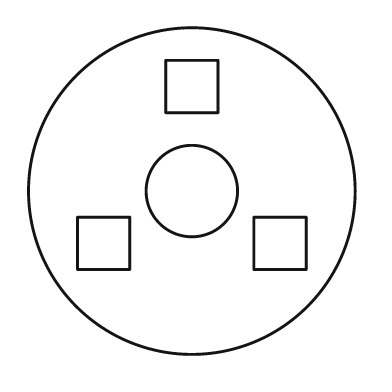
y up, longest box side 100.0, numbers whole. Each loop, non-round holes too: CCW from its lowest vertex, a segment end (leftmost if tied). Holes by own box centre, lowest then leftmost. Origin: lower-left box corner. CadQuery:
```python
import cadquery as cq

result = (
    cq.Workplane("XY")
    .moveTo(50.0, 50.0)
    .circle(50.0)
    .moveTo(15.0, 26.0)
    .lineTo(31.0, 26.0)
    .lineTo(31.0, 42.0)
    .lineTo(15.0, 42.0)
    .close()
    .moveTo(69.0, 26.0)
    .lineTo(85.0, 26.0)
    .lineTo(85.0, 42.0)
    .lineTo(69.0, 42.0)
    .close()
    .moveTo(50.0, 50.0)
    .circle(14.0)
    .moveTo(42.0, 74.0)
    .lineTo(58.0, 74.0)
    .lineTo(58.0, 90.0)
    .lineTo(42.0, 90.0)
    .close()
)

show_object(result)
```